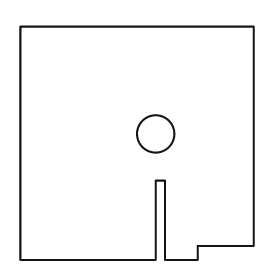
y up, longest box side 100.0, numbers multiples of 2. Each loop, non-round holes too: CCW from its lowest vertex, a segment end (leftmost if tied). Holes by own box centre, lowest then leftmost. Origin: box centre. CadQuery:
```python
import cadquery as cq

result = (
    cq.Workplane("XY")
    .moveTo(-50.0, -50.0)
    .lineTo(8.0, -50.0)
    .lineTo(8.0, -16.0)
    .lineTo(12.0, -16.0)
    .lineTo(12.0, -50.0)
    .lineTo(26.0, -50.0)
    .lineTo(26.0, -44.0)
    .lineTo(50.0, -44.0)
    .lineTo(50.0, 50.0)
    .lineTo(-50.0, 50.0)
    .close()
    .moveTo(8.0, 4.0)
    .circle(8.0)
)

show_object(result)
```